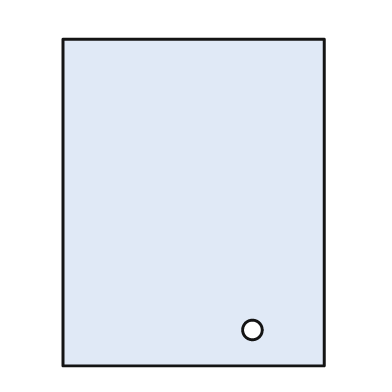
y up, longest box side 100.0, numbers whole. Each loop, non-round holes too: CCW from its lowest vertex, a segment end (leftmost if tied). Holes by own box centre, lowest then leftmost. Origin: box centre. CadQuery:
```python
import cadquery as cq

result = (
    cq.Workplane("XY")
    .moveTo(-40.0, -50.0)
    .lineTo(40.0, -50.0)
    .lineTo(40.0, 50.0)
    .lineTo(-40.0, 50.0)
    .close()
    .moveTo(18.0, -39.0)
    .circle(3.0)
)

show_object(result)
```